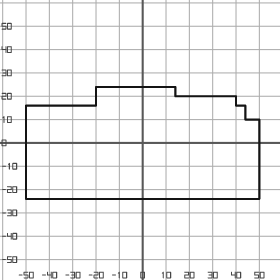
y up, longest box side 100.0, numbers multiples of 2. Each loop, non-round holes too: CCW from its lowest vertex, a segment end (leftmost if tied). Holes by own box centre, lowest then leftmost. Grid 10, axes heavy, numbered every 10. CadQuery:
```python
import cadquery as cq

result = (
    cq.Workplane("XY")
    .moveTo(-50.0, -24.0)
    .lineTo(50.0, -24.0)
    .lineTo(50.0, 10.0)
    .lineTo(44.0, 10.0)
    .lineTo(44.0, 16.0)
    .lineTo(40.0, 16.0)
    .lineTo(40.0, 20.0)
    .lineTo(14.0, 20.0)
    .lineTo(14.0, 24.0)
    .lineTo(-20.0, 24.0)
    .lineTo(-20.0, 16.0)
    .lineTo(-50.0, 16.0)
    .close()
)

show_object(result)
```